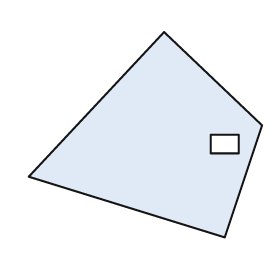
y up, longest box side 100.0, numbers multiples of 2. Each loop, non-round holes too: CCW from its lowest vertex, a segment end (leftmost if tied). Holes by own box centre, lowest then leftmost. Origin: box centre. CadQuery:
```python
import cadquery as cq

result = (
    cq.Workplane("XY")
    .moveTo(34.0, -44.0)
    .lineTo(50.0, 4.0)
    .lineTo(8.0, 44.0)
    .lineTo(-50.0, -18.0)
    .close()
    .moveTo(28.0, -8.0)
    .lineTo(40.0, -8.0)
    .lineTo(40.0, 0.0)
    .lineTo(28.0, 0.0)
    .close()
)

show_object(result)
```